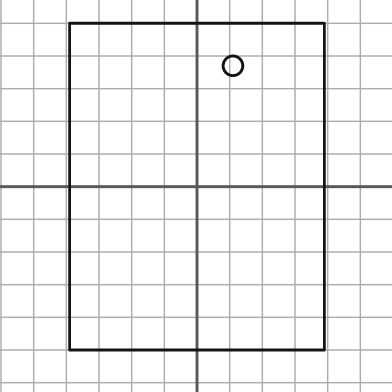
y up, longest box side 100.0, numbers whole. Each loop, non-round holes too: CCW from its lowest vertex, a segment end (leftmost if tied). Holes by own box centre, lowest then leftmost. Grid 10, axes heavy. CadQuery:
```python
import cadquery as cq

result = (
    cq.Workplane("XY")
    .moveTo(-39.0, -50.0)
    .lineTo(39.0, -50.0)
    .lineTo(39.0, 50.0)
    .lineTo(-39.0, 50.0)
    .close()
    .moveTo(11.0, 37.0)
    .circle(3.0)
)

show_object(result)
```